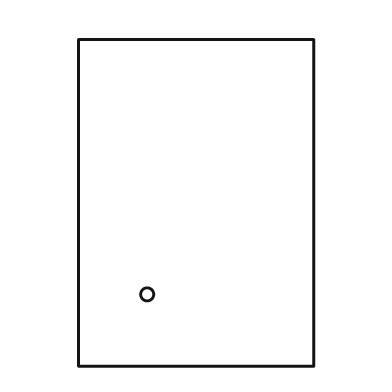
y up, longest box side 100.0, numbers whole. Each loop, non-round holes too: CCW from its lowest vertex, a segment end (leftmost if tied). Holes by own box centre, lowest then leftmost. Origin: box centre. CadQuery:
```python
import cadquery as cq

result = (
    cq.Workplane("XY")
    .moveTo(-36.0, -50.0)
    .lineTo(36.0, -50.0)
    .lineTo(36.0, 50.0)
    .lineTo(-36.0, 50.0)
    .close()
    .moveTo(-15.0, -28.0)
    .circle(2.0)
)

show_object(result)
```